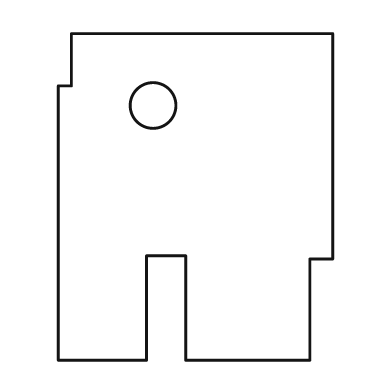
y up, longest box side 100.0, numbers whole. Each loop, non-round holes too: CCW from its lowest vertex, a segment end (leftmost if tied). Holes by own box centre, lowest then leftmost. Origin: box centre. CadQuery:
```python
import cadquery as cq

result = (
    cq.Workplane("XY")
    .moveTo(-42.0, -50.0)
    .lineTo(-15.0, -50.0)
    .lineTo(-15.0, -18.0)
    .lineTo(-3.0, -18.0)
    .lineTo(-3.0, -50.0)
    .lineTo(35.0, -50.0)
    .lineTo(35.0, -19.0)
    .lineTo(42.0, -19.0)
    .lineTo(42.0, 50.0)
    .lineTo(-38.0, 50.0)
    .lineTo(-38.0, 34.0)
    .lineTo(-42.0, 34.0)
    .close()
    .moveTo(-13.0, 28.0)
    .circle(7.0)
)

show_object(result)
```